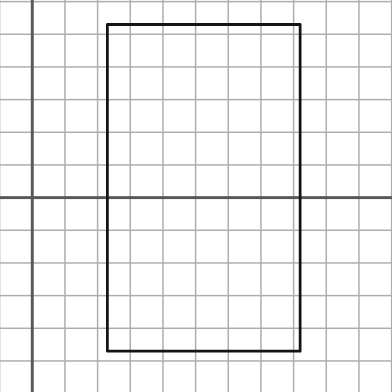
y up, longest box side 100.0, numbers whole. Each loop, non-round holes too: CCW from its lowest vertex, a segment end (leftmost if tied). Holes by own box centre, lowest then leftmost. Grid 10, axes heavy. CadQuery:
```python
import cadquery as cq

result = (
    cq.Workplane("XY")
    .moveTo(23.0, -47.0)
    .lineTo(82.0, -47.0)
    .lineTo(82.0, 53.0)
    .lineTo(23.0, 53.0)
    .close()
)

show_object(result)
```